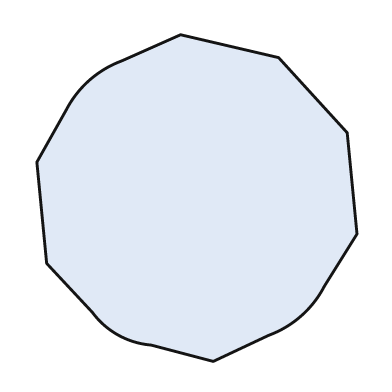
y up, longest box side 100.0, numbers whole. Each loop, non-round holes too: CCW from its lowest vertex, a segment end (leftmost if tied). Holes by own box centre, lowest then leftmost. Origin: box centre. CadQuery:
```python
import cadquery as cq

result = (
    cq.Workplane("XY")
    .moveTo(5.0, -50.0)
    .lineTo(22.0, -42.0)
    .threePointArc((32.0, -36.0), (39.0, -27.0))
    .lineTo(49.0, -11.0)
    .lineTo(46.0, 20.0)
    .lineTo(25.0, 43.0)
    .lineTo(-5.0, 50.0)
    .lineTo(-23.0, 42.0)
    .threePointArc((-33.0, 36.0), (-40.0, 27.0))
    .lineTo(-49.0, 11.0)
    .lineTo(-46.0, -20.0)
    .lineTo(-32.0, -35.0)
    .threePointArc((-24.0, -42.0), (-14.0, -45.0))
    .close()
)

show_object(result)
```